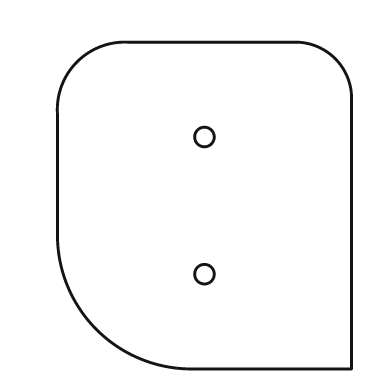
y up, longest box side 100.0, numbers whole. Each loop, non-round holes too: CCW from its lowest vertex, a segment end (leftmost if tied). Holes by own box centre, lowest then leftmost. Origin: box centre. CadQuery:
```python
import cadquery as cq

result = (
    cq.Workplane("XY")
    .moveTo(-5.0, -50.0)
    .lineTo(45.0, -50.0)
    .lineTo(45.0, 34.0)
    .threePointArc((40.0, 45.0), (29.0, 50.0))
    .lineTo(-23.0, 50.0)
    .threePointArc((-39.0, 44.0), (-45.0, 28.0))
    .lineTo(-45.0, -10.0)
    .threePointArc((-33.0, -38.0), (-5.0, -50.0))
    .close()
    .moveTo(0.0, -21.0)
    .circle(3.0)
    .moveTo(0.0, 21.0)
    .circle(3.0)
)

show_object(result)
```